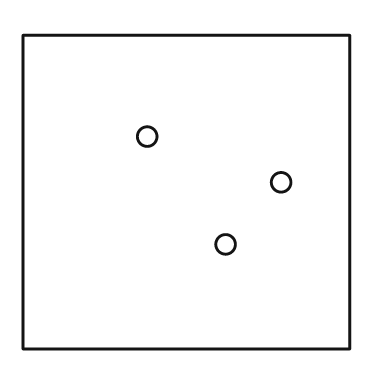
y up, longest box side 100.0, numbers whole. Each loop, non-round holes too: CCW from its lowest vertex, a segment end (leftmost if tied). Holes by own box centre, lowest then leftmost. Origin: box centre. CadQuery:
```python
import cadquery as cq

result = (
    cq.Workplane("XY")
    .moveTo(-50.0, -48.0)
    .lineTo(50.0, -48.0)
    .lineTo(50.0, 48.0)
    .lineTo(-50.0, 48.0)
    .close()
    .moveTo(12.0, -16.0)
    .circle(3.0)
    .moveTo(29.0, 3.0)
    .circle(3.0)
    .moveTo(-12.0, 17.0)
    .circle(3.0)
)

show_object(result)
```